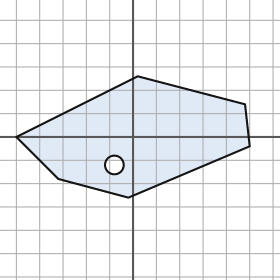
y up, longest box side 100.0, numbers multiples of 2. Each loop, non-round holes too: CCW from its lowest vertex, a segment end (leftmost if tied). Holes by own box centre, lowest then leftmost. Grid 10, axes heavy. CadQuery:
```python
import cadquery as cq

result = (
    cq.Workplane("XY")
    .moveTo(-2.0, -26.0)
    .lineTo(50.0, -4.0)
    .lineTo(48.0, 14.0)
    .lineTo(2.0, 26.0)
    .lineTo(-50.0, 0.0)
    .lineTo(-32.0, -18.0)
    .close()
    .moveTo(-8.0, -12.0)
    .circle(4.0)
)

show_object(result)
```